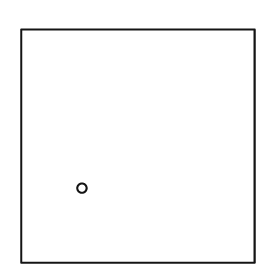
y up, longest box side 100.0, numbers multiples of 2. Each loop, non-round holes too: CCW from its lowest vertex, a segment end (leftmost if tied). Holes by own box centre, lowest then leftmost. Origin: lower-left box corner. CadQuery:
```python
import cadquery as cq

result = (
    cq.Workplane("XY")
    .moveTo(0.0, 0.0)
    .lineTo(100.0, 0.0)
    .lineTo(100.0, 100.0)
    .lineTo(0.0, 100.0)
    .close()
    .moveTo(26.0, 32.0)
    .circle(2.0)
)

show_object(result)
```